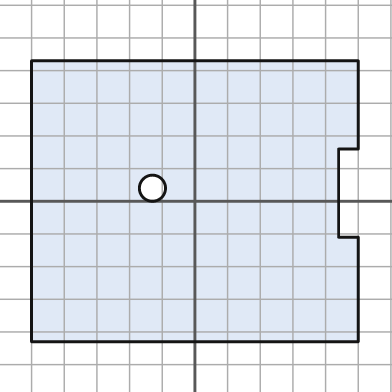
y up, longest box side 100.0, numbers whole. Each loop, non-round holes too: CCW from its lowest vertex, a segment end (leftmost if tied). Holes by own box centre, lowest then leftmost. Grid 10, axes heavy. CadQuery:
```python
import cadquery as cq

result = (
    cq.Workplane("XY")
    .moveTo(-50.0, -43.0)
    .lineTo(50.0, -43.0)
    .lineTo(50.0, -11.0)
    .lineTo(44.0, -11.0)
    .lineTo(44.0, 16.0)
    .lineTo(50.0, 16.0)
    .lineTo(50.0, 43.0)
    .lineTo(-50.0, 43.0)
    .close()
    .moveTo(-13.0, 4.0)
    .circle(4.0)
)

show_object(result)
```